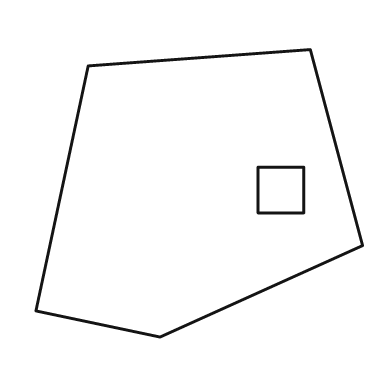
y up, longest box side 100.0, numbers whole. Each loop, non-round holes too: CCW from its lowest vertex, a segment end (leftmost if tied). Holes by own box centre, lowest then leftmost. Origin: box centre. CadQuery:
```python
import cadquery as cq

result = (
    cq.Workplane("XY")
    .moveTo(-12.0, -44.0)
    .lineTo(50.0, -16.0)
    .lineTo(34.0, 44.0)
    .lineTo(-34.0, 39.0)
    .lineTo(-50.0, -36.0)
    .close()
    .moveTo(18.0, -6.0)
    .lineTo(32.0, -6.0)
    .lineTo(32.0, 8.0)
    .lineTo(18.0, 8.0)
    .close()
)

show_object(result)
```